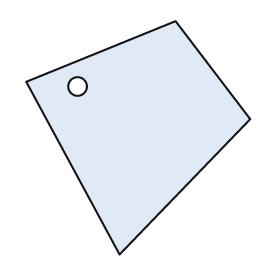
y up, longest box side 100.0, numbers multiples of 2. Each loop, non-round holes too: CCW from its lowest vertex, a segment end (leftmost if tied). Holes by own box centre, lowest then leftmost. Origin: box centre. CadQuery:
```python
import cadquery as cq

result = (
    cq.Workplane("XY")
    .moveTo(-8.0, -50.0)
    .lineTo(48.0, 8.0)
    .lineTo(16.0, 50.0)
    .lineTo(-48.0, 24.0)
    .close()
    .moveTo(-26.0, 22.0)
    .circle(4.0)
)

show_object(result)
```